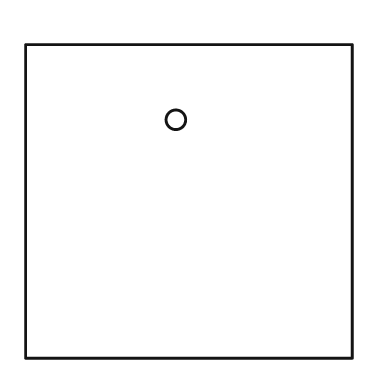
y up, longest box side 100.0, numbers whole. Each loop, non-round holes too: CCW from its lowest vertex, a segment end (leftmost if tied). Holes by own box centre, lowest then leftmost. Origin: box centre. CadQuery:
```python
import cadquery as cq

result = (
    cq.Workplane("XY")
    .moveTo(-50.0, -48.0)
    .lineTo(50.0, -48.0)
    .lineTo(50.0, 48.0)
    .lineTo(-50.0, 48.0)
    .close()
    .moveTo(-4.0, 25.0)
    .circle(3.0)
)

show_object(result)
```